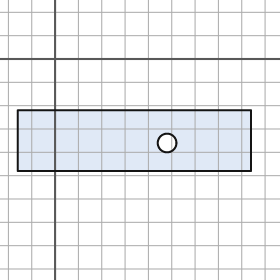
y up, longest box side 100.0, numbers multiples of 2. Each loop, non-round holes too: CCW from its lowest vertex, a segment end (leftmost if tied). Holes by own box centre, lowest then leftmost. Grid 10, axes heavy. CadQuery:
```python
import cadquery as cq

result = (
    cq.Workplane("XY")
    .moveTo(-16.0, -48.0)
    .lineTo(84.0, -48.0)
    .lineTo(84.0, -22.0)
    .lineTo(-16.0, -22.0)
    .close()
    .moveTo(48.0, -36.0)
    .circle(4.0)
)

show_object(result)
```